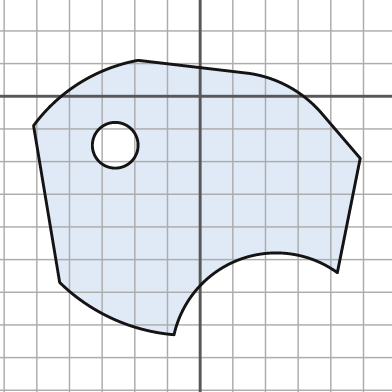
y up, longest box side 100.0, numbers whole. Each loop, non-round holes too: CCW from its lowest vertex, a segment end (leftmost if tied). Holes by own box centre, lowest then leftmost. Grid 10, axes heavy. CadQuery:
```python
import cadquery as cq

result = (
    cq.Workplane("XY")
    .moveTo(-8.0, -73.0)
    .threePointArc((12.0, -50.0), (42.0, -54.0))
    .lineTo(49.0, -19.0)
    .lineTo(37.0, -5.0)
    .threePointArc((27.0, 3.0), (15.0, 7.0))
    .lineTo(-19.0, 11.0)
    .threePointArc((-37.0, 4.0), (-51.0, -9.0))
    .lineTo(-43.0, -57.0)
    .threePointArc((-27.0, -68.0), (-8.0, -73.0))
    .close()
    .moveTo(-26.0, -15.0)
    .circle(7.0)
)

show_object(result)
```